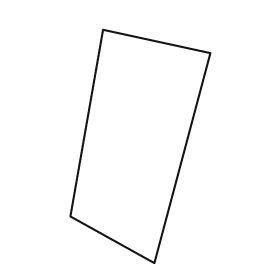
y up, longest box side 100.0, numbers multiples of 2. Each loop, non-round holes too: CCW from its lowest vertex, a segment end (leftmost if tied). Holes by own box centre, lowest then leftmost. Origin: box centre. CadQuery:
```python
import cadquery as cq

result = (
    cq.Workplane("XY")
    .moveTo(6.0, -50.0)
    .lineTo(30.0, 40.0)
    .lineTo(-16.0, 50.0)
    .lineTo(-30.0, -30.0)
    .close()
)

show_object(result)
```